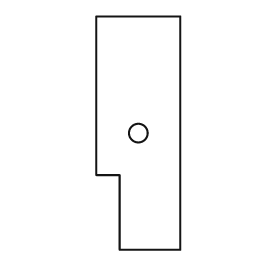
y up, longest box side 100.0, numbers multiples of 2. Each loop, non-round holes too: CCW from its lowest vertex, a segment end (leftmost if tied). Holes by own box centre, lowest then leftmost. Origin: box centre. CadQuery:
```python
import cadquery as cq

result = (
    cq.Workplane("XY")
    .moveTo(-8.0, -50.0)
    .lineTo(18.0, -50.0)
    .lineTo(18.0, 50.0)
    .lineTo(-18.0, 50.0)
    .lineTo(-18.0, -18.0)
    .lineTo(-8.0, -18.0)
    .close()
    .moveTo(0.0, 0.0)
    .circle(4.0)
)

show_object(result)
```